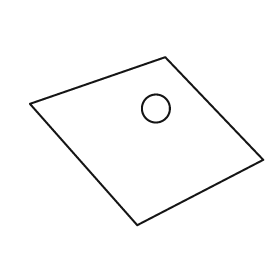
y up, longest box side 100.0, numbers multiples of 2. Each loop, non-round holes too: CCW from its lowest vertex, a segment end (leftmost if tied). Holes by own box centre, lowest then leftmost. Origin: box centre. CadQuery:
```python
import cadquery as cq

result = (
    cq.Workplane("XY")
    .moveTo(-4.0, -36.0)
    .lineTo(50.0, -8.0)
    .lineTo(8.0, 36.0)
    .lineTo(-50.0, 16.0)
    .close()
    .moveTo(4.0, 14.0)
    .circle(6.0)
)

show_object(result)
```